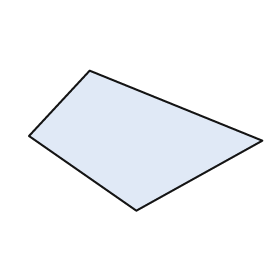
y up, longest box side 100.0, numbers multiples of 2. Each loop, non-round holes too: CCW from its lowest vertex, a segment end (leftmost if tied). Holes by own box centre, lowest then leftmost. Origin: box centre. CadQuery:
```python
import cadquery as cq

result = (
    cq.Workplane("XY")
    .moveTo(-4.0, -30.0)
    .lineTo(50.0, 0.0)
    .lineTo(-24.0, 30.0)
    .lineTo(-50.0, 2.0)
    .close()
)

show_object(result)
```